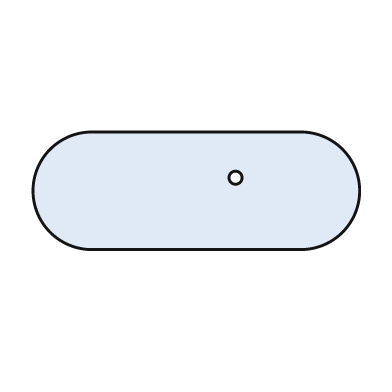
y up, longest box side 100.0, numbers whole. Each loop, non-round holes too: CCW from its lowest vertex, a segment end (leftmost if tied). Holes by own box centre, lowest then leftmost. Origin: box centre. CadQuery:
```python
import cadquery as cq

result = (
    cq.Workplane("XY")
    .moveTo(-32.0, -18.0)
    .lineTo(32.0, -18.0)
    .threePointArc((50.0, 0.0), (32.0, 18.0))
    .lineTo(-32.0, 18.0)
    .threePointArc((-50.0, 0.0), (-32.0, -18.0))
    .close()
    .moveTo(12.0, 4.0)
    .circle(2.0)
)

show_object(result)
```